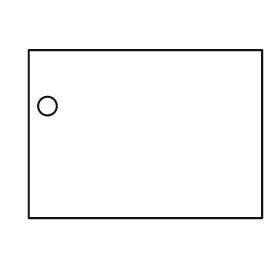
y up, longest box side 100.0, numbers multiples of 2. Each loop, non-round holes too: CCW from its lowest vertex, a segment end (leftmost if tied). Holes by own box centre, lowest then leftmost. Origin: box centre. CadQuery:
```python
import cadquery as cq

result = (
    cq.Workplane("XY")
    .moveTo(-50.0, -36.0)
    .lineTo(50.0, -36.0)
    .lineTo(50.0, 36.0)
    .lineTo(-50.0, 36.0)
    .close()
    .moveTo(-42.0, 12.0)
    .circle(4.0)
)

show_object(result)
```